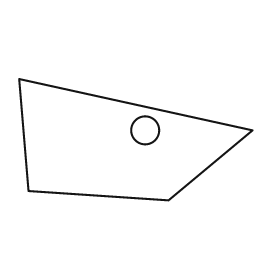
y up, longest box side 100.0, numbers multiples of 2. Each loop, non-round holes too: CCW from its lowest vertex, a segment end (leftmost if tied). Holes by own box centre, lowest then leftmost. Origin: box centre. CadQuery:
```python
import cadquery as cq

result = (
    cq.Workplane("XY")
    .moveTo(14.0, -26.0)
    .lineTo(50.0, 4.0)
    .lineTo(-50.0, 26.0)
    .lineTo(-46.0, -22.0)
    .close()
    .moveTo(4.0, 4.0)
    .circle(6.0)
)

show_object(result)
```